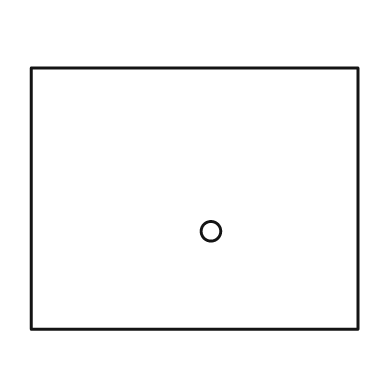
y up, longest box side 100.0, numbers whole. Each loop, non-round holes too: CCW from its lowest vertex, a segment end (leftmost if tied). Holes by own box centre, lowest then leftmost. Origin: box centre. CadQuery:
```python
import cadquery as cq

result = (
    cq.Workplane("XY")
    .moveTo(-50.0, -40.0)
    .lineTo(50.0, -40.0)
    .lineTo(50.0, 40.0)
    .lineTo(-50.0, 40.0)
    .close()
    .moveTo(5.0, -10.0)
    .circle(3.0)
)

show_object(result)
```